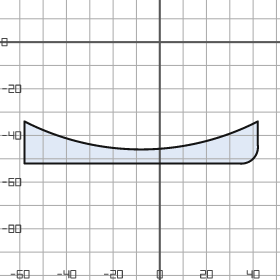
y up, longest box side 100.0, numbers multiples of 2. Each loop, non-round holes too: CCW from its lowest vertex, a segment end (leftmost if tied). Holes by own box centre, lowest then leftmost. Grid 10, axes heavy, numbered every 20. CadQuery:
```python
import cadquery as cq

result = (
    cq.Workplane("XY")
    .moveTo(-58.0, -52.0)
    .lineTo(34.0, -52.0)
    .threePointArc((40.0, -50.0), (42.0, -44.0))
    .lineTo(42.0, -34.0)
    .threePointArc((-8.0, -46.0), (-58.0, -34.0))
    .close()
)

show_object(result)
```